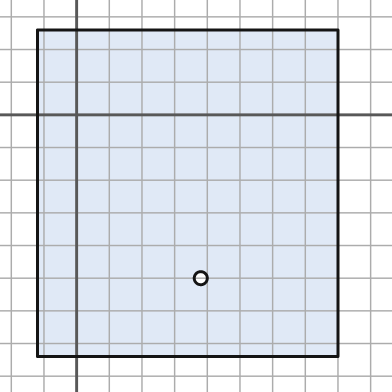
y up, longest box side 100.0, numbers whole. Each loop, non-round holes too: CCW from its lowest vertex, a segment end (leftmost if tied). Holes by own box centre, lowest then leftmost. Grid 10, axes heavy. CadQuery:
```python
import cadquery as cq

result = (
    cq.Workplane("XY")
    .moveTo(-12.0, -74.0)
    .lineTo(80.0, -74.0)
    .lineTo(80.0, 26.0)
    .lineTo(-12.0, 26.0)
    .close()
    .moveTo(38.0, -50.0)
    .circle(2.0)
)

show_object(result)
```